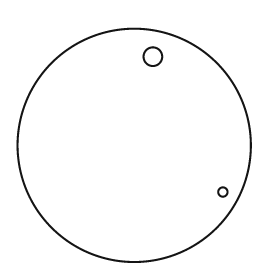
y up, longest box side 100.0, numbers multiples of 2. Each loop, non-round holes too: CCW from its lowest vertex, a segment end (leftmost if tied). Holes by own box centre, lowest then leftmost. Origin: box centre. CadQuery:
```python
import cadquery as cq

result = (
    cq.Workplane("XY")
    .moveTo(0.0, 0.0)
    .circle(50.0)
    .moveTo(38.0, -20.0)
    .circle(2.0)
    .moveTo(8.0, 38.0)
    .circle(4.0)
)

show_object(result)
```